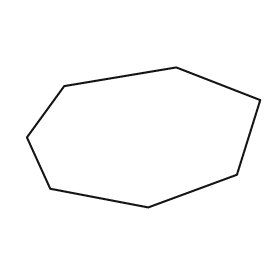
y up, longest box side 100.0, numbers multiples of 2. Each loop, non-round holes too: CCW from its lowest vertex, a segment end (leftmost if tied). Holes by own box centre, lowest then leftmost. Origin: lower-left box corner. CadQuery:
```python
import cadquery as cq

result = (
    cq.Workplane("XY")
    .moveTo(52.0, 0.0)
    .lineTo(90.0, 14.0)
    .lineTo(100.0, 46.0)
    .lineTo(64.0, 60.0)
    .lineTo(16.0, 52.0)
    .lineTo(0.0, 30.0)
    .lineTo(10.0, 8.0)
    .close()
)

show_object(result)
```